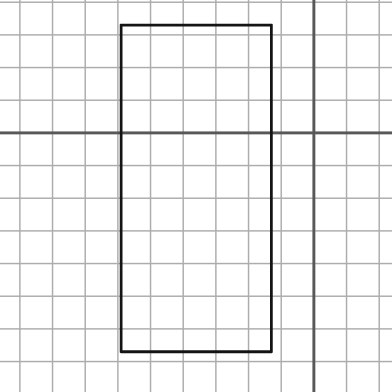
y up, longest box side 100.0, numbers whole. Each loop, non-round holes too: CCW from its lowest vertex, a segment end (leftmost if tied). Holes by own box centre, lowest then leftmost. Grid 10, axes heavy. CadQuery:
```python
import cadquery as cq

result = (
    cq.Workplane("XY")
    .moveTo(-59.0, -67.0)
    .lineTo(-13.0, -67.0)
    .lineTo(-13.0, 33.0)
    .lineTo(-59.0, 33.0)
    .close()
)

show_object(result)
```